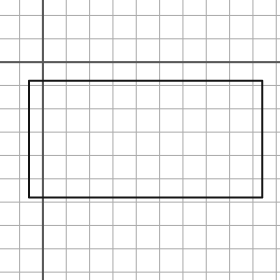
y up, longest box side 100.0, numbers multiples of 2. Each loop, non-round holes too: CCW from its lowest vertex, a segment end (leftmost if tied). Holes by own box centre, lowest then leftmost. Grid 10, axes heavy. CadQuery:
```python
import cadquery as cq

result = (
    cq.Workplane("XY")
    .moveTo(-6.0, -58.0)
    .lineTo(94.0, -58.0)
    .lineTo(94.0, -8.0)
    .lineTo(-6.0, -8.0)
    .close()
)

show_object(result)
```